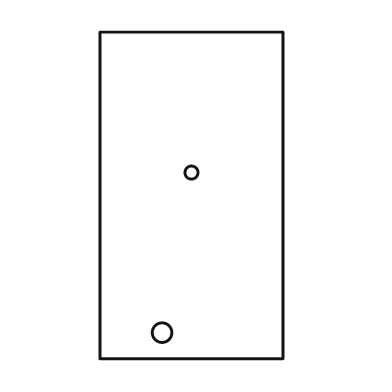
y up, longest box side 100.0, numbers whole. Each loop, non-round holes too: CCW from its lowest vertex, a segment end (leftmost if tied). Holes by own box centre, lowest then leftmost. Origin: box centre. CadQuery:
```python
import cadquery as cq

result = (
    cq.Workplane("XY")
    .moveTo(-28.0, -50.0)
    .lineTo(28.0, -50.0)
    .lineTo(28.0, 50.0)
    .lineTo(-28.0, 50.0)
    .close()
    .moveTo(-9.0, -42.0)
    .circle(3.0)
    .moveTo(0.0, 7.0)
    .circle(2.0)
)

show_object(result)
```